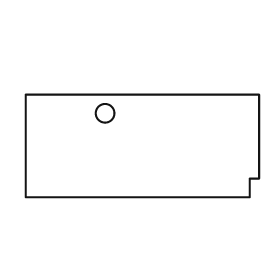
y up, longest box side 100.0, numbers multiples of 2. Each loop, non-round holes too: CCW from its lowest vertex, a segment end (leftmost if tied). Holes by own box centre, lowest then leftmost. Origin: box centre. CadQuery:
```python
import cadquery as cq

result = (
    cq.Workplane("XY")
    .moveTo(-50.0, -22.0)
    .lineTo(46.0, -22.0)
    .lineTo(46.0, -14.0)
    .lineTo(50.0, -14.0)
    .lineTo(50.0, 22.0)
    .lineTo(-50.0, 22.0)
    .close()
    .moveTo(-16.0, 14.0)
    .circle(4.0)
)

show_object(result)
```